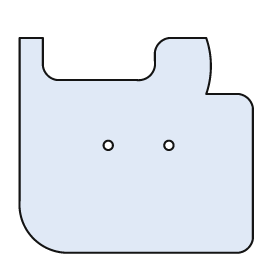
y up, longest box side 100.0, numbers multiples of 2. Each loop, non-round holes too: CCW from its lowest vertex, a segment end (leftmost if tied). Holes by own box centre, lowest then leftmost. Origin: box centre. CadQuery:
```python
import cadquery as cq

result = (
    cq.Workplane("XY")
    .moveTo(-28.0, -46.0)
    .lineTo(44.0, -46.0)
    .threePointArc((48.0, -44.0), (50.0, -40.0))
    .lineTo(50.0, 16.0)
    .threePointArc((48.0, 20.0), (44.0, 22.0))
    .lineTo(30.0, 22.0)
    .threePointArc((32.0, 34.0), (30.0, 46.0))
    .lineTo(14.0, 46.0)
    .threePointArc((10.0, 44.0), (8.0, 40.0))
    .lineTo(8.0, 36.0)
    .threePointArc((6.0, 30.0), (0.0, 28.0))
    .lineTo(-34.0, 28.0)
    .threePointArc((-38.0, 30.0), (-40.0, 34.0))
    .lineTo(-40.0, 46.0)
    .lineTo(-50.0, 46.0)
    .lineTo(-50.0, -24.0)
    .threePointArc((-44.0, -40.0), (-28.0, -46.0))
    .close()
    .moveTo(-12.0, 0.0)
    .circle(2.0)
    .moveTo(14.0, 0.0)
    .circle(2.0)
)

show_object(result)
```